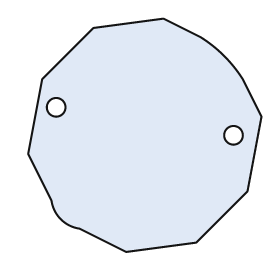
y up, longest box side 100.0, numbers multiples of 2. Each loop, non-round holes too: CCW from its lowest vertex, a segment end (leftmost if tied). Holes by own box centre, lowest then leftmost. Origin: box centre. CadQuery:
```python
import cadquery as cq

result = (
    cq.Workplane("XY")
    .moveTo(-8.0, -50.0)
    .lineTo(22.0, -46.0)
    .lineTo(44.0, -24.0)
    .lineTo(50.0, 8.0)
    .lineTo(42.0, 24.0)
    .threePointArc((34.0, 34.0), (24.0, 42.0))
    .lineTo(8.0, 50.0)
    .lineTo(-22.0, 46.0)
    .lineTo(-44.0, 24.0)
    .lineTo(-50.0, -8.0)
    .lineTo(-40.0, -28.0)
    .threePointArc((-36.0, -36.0), (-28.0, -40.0))
    .close()
    .moveTo(38.0, 0.0)
    .circle(4.0)
    .moveTo(-38.0, 12.0)
    .circle(4.0)
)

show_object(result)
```